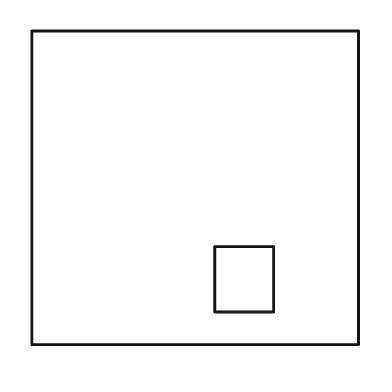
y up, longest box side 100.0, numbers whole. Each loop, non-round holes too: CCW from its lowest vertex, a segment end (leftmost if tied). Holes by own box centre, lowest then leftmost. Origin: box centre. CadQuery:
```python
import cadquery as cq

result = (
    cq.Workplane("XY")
    .moveTo(-50.0, -48.0)
    .lineTo(50.0, -48.0)
    .lineTo(50.0, 48.0)
    .lineTo(-50.0, 48.0)
    .close()
    .moveTo(6.0, -38.0)
    .lineTo(24.0, -38.0)
    .lineTo(24.0, -18.0)
    .lineTo(6.0, -18.0)
    .close()
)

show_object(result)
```